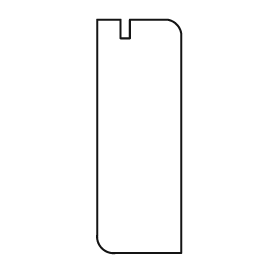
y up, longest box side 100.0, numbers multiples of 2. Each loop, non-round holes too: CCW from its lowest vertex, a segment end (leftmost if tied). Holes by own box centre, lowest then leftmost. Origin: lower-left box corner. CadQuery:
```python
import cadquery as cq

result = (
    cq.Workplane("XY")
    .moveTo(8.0, 0.0)
    .lineTo(36.0, 0.0)
    .lineTo(36.0, 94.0)
    .threePointArc((34.0, 98.0), (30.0, 100.0))
    .lineTo(14.0, 100.0)
    .lineTo(14.0, 92.0)
    .lineTo(10.0, 92.0)
    .lineTo(10.0, 100.0)
    .lineTo(0.0, 100.0)
    .lineTo(0.0, 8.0)
    .threePointArc((2.0, 2.0), (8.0, 0.0))
    .close()
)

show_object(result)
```